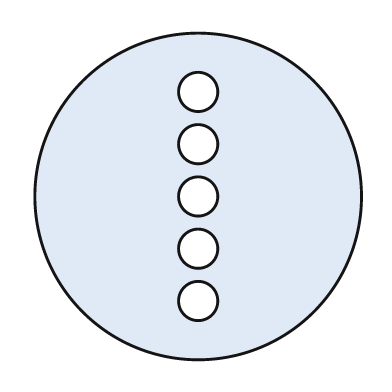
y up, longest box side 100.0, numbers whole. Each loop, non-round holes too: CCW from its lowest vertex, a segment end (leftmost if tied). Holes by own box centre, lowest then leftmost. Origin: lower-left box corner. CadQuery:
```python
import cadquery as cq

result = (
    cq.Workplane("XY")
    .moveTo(50.0, 50.0)
    .circle(50.0)
    .moveTo(50.0, 18.0)
    .circle(6.0)
    .moveTo(50.0, 34.0)
    .circle(6.0)
    .moveTo(50.0, 50.0)
    .circle(6.0)
    .moveTo(50.0, 66.0)
    .circle(6.0)
    .moveTo(50.0, 82.0)
    .circle(6.0)
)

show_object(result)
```